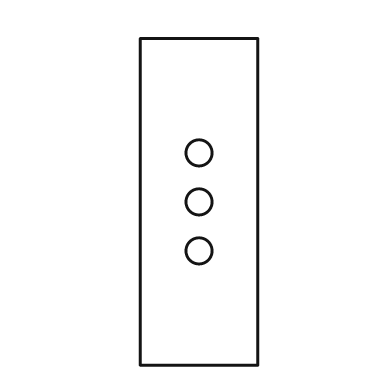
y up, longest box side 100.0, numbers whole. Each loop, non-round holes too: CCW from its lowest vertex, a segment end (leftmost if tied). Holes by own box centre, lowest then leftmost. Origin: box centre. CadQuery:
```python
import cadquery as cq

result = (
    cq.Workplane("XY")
    .moveTo(-18.0, -50.0)
    .lineTo(18.0, -50.0)
    .lineTo(18.0, 50.0)
    .lineTo(-18.0, 50.0)
    .close()
    .moveTo(0.0, -15.0)
    .circle(4.0)
    .moveTo(0.0, 0.0)
    .circle(4.0)
    .moveTo(0.0, 15.0)
    .circle(4.0)
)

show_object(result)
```